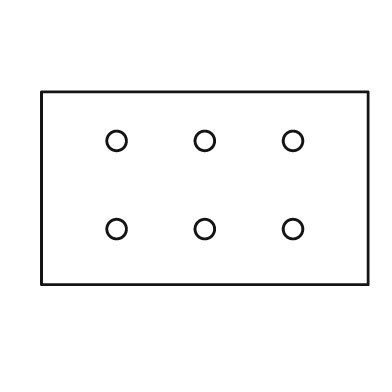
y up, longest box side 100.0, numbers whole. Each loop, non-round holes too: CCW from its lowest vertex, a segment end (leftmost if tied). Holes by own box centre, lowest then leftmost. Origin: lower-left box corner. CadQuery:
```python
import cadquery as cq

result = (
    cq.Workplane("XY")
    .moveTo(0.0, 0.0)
    .lineTo(100.0, 0.0)
    .lineTo(100.0, 59.0)
    .lineTo(0.0, 59.0)
    .close()
    .moveTo(23.0, 17.0)
    .circle(3.0)
    .moveTo(50.0, 17.0)
    .circle(3.0)
    .moveTo(77.0, 17.0)
    .circle(3.0)
    .moveTo(23.0, 44.0)
    .circle(3.0)
    .moveTo(50.0, 44.0)
    .circle(3.0)
    .moveTo(77.0, 44.0)
    .circle(3.0)
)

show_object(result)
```